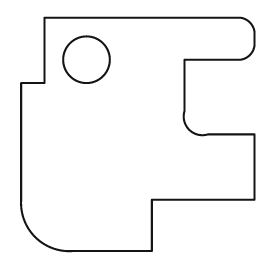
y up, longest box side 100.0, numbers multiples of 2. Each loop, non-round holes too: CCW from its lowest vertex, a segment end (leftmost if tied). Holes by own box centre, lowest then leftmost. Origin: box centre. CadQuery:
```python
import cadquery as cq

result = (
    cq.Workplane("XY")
    .moveTo(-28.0, -50.0)
    .lineTo(6.0, -50.0)
    .lineTo(6.0, -28.0)
    .lineTo(50.0, -28.0)
    .lineTo(50.0, 0.0)
    .lineTo(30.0, 0.0)
    .threePointArc((22.0, 2.0), (20.0, 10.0))
    .lineTo(20.0, 32.0)
    .lineTo(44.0, 32.0)
    .threePointArc((48.0, 34.0), (50.0, 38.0))
    .lineTo(50.0, 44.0)
    .threePointArc((48.0, 48.0), (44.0, 50.0))
    .lineTo(-40.0, 50.0)
    .lineTo(-40.0, 22.0)
    .lineTo(-50.0, 22.0)
    .lineTo(-50.0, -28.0)
    .threePointArc((-44.0, -44.0), (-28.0, -50.0))
    .close()
    .moveTo(-22.0, 32.0)
    .circle(10.0)
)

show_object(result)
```